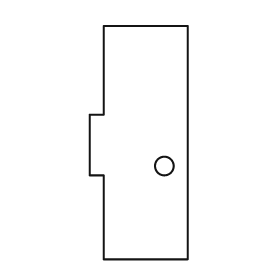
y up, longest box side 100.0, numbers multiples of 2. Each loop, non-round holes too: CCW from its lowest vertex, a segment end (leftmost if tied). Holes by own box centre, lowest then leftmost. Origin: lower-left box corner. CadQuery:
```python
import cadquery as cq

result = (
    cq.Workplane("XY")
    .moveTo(6.0, 0.0)
    .lineTo(42.0, 0.0)
    .lineTo(42.0, 100.0)
    .lineTo(6.0, 100.0)
    .lineTo(6.0, 62.0)
    .lineTo(0.0, 62.0)
    .lineTo(0.0, 36.0)
    .lineTo(6.0, 36.0)
    .close()
    .moveTo(32.0, 40.0)
    .circle(4.0)
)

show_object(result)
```